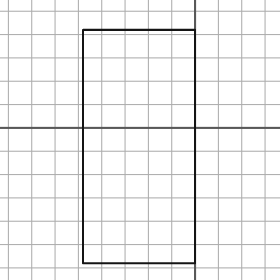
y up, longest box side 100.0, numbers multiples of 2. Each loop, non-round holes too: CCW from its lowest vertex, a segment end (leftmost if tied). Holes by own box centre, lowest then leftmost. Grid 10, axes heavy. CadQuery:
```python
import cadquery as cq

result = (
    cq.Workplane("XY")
    .moveTo(-48.0, -58.0)
    .lineTo(0.0, -58.0)
    .lineTo(0.0, 42.0)
    .lineTo(-48.0, 42.0)
    .close()
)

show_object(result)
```